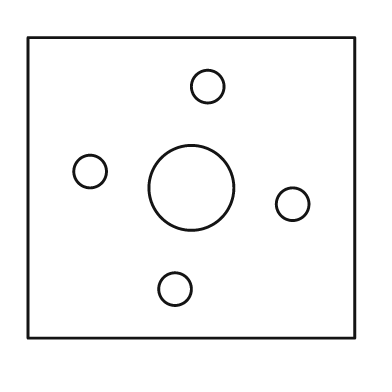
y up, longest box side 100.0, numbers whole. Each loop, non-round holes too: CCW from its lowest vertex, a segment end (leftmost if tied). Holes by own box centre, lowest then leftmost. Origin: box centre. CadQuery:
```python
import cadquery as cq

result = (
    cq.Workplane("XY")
    .moveTo(-50.0, -46.0)
    .lineTo(50.0, -46.0)
    .lineTo(50.0, 46.0)
    .lineTo(-50.0, 46.0)
    .close()
    .moveTo(-5.0, -31.0)
    .circle(5.0)
    .moveTo(31.0, -5.0)
    .circle(5.0)
    .moveTo(0.0, 0.0)
    .circle(13.0)
    .moveTo(-31.0, 5.0)
    .circle(5.0)
    .moveTo(5.0, 31.0)
    .circle(5.0)
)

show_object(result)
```